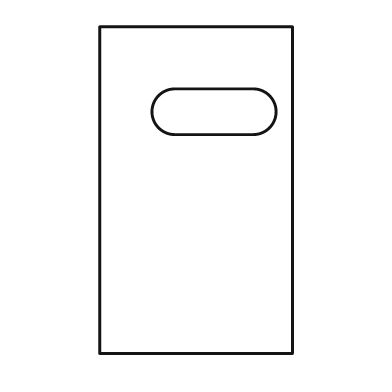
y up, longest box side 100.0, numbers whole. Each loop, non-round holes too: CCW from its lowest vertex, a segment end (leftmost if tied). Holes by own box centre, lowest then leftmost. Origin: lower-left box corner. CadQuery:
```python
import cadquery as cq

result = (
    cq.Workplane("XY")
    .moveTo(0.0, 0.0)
    .lineTo(59.0, 0.0)
    .lineTo(59.0, 100.0)
    .lineTo(0.0, 100.0)
    .close()
    .moveTo(23.0, 67.0)
    .lineTo(47.0, 67.0)
    .threePointArc((54.0, 74.0), (47.0, 81.0))
    .lineTo(23.0, 81.0)
    .threePointArc((16.0, 74.0), (23.0, 67.0))
    .close()
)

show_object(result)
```